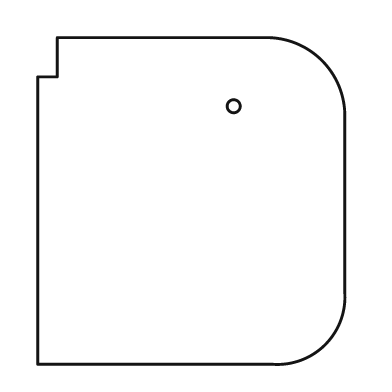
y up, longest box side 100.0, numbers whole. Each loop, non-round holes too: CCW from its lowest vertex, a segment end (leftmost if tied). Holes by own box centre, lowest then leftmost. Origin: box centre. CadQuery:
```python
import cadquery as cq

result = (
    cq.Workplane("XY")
    .moveTo(-47.0, -50.0)
    .lineTo(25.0, -50.0)
    .threePointArc((41.0, -44.0), (47.0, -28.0))
    .lineTo(47.0, 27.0)
    .threePointArc((40.0, 43.0), (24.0, 50.0))
    .lineTo(-41.0, 50.0)
    .lineTo(-41.0, 38.0)
    .lineTo(-47.0, 38.0)
    .close()
    .moveTo(13.0, 29.0)
    .circle(2.0)
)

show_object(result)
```